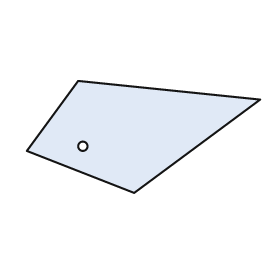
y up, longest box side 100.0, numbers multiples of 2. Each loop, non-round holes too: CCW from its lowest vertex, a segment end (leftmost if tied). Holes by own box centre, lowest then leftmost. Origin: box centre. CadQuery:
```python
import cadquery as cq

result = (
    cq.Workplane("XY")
    .moveTo(-4.0, -24.0)
    .lineTo(50.0, 16.0)
    .lineTo(-28.0, 24.0)
    .lineTo(-50.0, -6.0)
    .close()
    .moveTo(-26.0, -4.0)
    .circle(2.0)
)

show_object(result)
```